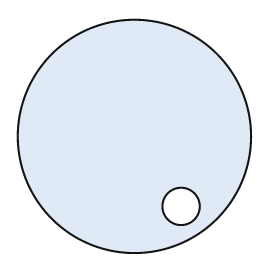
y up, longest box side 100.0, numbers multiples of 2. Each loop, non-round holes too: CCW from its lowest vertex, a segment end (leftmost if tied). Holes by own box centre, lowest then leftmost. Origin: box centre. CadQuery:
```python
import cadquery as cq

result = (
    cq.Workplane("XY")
    .moveTo(0.0, 0.0)
    .circle(50.0)
    .moveTo(20.0, -30.0)
    .circle(8.0)
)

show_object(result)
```